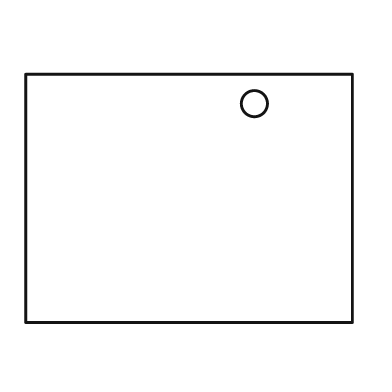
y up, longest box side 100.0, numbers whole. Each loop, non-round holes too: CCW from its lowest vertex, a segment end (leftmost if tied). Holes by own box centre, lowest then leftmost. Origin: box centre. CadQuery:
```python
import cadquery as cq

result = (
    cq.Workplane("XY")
    .moveTo(-50.0, -38.0)
    .lineTo(50.0, -38.0)
    .lineTo(50.0, 38.0)
    .lineTo(-50.0, 38.0)
    .close()
    .moveTo(20.0, 29.0)
    .circle(4.0)
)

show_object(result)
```